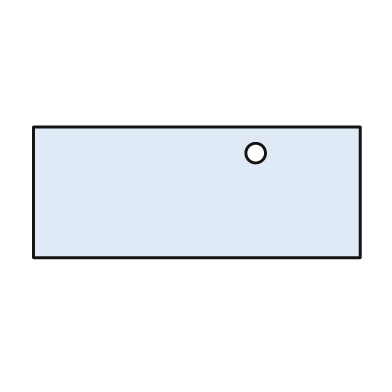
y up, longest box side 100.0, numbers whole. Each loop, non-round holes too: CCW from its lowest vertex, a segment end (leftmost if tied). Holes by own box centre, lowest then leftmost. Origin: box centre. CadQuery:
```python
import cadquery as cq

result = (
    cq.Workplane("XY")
    .moveTo(-50.0, -20.0)
    .lineTo(50.0, -20.0)
    .lineTo(50.0, 20.0)
    .lineTo(-50.0, 20.0)
    .close()
    .moveTo(18.0, 12.0)
    .circle(3.0)
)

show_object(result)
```